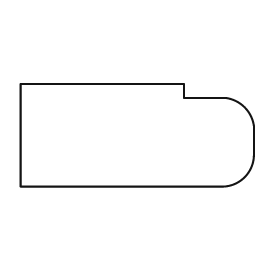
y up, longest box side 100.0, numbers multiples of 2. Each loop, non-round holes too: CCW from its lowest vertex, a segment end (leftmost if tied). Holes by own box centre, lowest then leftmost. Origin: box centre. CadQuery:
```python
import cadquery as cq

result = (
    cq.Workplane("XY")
    .moveTo(-50.0, -22.0)
    .lineTo(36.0, -22.0)
    .threePointArc((46.0, -18.0), (50.0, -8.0))
    .lineTo(50.0, 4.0)
    .threePointArc((46.0, 12.0), (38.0, 16.0))
    .lineTo(20.0, 16.0)
    .lineTo(20.0, 22.0)
    .lineTo(-50.0, 22.0)
    .close()
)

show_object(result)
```